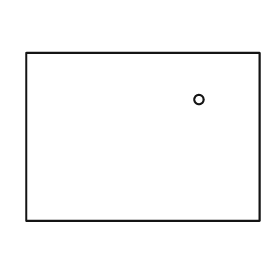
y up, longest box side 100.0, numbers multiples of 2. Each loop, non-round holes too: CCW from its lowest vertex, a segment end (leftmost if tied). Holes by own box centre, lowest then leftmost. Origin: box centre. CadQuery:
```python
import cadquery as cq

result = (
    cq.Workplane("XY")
    .moveTo(-50.0, -36.0)
    .lineTo(50.0, -36.0)
    .lineTo(50.0, 36.0)
    .lineTo(-50.0, 36.0)
    .close()
    .moveTo(24.0, 16.0)
    .circle(2.0)
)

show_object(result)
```